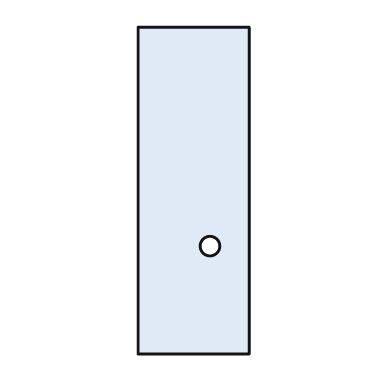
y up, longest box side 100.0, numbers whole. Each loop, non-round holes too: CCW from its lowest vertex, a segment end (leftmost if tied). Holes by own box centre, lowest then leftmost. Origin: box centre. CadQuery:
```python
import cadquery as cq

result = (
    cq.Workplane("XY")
    .moveTo(-17.0, -50.0)
    .lineTo(17.0, -50.0)
    .lineTo(17.0, 50.0)
    .lineTo(-17.0, 50.0)
    .close()
    .moveTo(5.0, -17.0)
    .circle(3.0)
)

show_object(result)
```